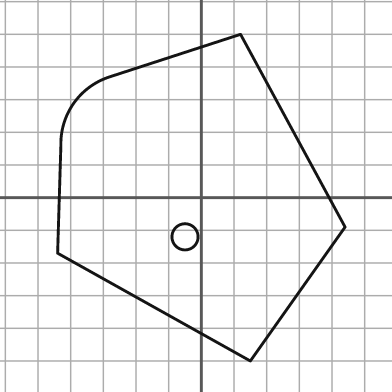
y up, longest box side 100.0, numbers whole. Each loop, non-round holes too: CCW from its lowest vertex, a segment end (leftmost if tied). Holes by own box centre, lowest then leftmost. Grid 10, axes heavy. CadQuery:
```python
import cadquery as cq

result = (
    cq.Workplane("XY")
    .moveTo(15.0, -50.0)
    .lineTo(44.0, -9.0)
    .lineTo(12.0, 50.0)
    .lineTo(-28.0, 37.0)
    .threePointArc((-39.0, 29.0), (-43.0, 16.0))
    .lineTo(-44.0, -17.0)
    .close()
    .moveTo(-5.0, -12.0)
    .circle(4.0)
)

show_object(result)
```